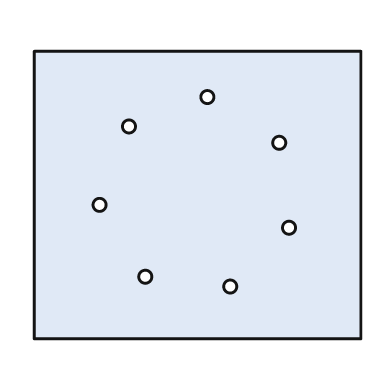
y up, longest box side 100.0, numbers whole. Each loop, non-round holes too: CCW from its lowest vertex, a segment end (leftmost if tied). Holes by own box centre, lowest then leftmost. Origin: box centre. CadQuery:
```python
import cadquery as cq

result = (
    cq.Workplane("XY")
    .moveTo(-50.0, -44.0)
    .lineTo(50.0, -44.0)
    .lineTo(50.0, 44.0)
    .lineTo(-50.0, 44.0)
    .close()
    .moveTo(10.0, -28.0)
    .circle(2.0)
    .moveTo(-16.0, -25.0)
    .circle(2.0)
    .moveTo(28.0, -10.0)
    .circle(2.0)
    .moveTo(-30.0, -3.0)
    .circle(2.0)
    .moveTo(25.0, 16.0)
    .circle(2.0)
    .moveTo(-21.0, 21.0)
    .circle(2.0)
    .moveTo(3.0, 30.0)
    .circle(2.0)
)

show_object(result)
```